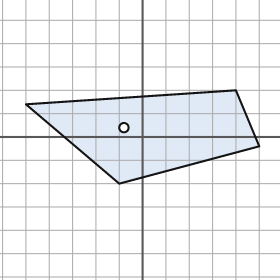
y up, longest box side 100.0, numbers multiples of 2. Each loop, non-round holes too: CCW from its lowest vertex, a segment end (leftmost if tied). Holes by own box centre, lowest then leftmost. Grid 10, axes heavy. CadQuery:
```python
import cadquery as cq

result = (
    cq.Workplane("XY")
    .moveTo(-10.0, -20.0)
    .lineTo(50.0, -4.0)
    .lineTo(40.0, 20.0)
    .lineTo(-50.0, 14.0)
    .close()
    .moveTo(-8.0, 4.0)
    .circle(2.0)
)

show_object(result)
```